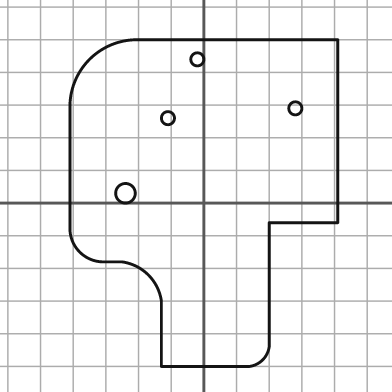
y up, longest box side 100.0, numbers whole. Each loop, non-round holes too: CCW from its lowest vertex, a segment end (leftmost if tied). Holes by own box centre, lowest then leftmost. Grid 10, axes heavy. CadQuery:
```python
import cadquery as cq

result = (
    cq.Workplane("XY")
    .moveTo(-13.0, -50.0)
    .lineTo(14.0, -50.0)
    .threePointArc((18.0, -48.0), (20.0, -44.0))
    .lineTo(20.0, -6.0)
    .lineTo(41.0, -6.0)
    .lineTo(41.0, 50.0)
    .lineTo(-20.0, 50.0)
    .threePointArc((-35.0, 44.0), (-41.0, 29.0))
    .lineTo(-41.0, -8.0)
    .threePointArc((-38.0, -15.0), (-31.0, -18.0))
    .lineTo(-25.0, -18.0)
    .threePointArc((-17.0, -22.0), (-13.0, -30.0))
    .close()
    .moveTo(-24.0, 3.0)
    .circle(3.0)
    .moveTo(-11.0, 26.0)
    .circle(2.0)
    .moveTo(28.0, 29.0)
    .circle(2.0)
    .moveTo(-2.0, 44.0)
    .circle(2.0)
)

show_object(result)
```